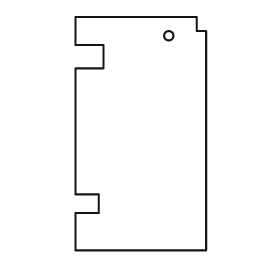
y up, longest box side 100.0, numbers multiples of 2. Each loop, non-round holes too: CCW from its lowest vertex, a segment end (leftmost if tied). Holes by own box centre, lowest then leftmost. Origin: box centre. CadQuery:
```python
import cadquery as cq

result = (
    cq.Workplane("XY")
    .moveTo(-28.0, -50.0)
    .lineTo(28.0, -50.0)
    .lineTo(28.0, 44.0)
    .lineTo(24.0, 44.0)
    .lineTo(24.0, 50.0)
    .lineTo(-28.0, 50.0)
    .lineTo(-28.0, 38.0)
    .lineTo(-16.0, 38.0)
    .lineTo(-16.0, 28.0)
    .lineTo(-28.0, 28.0)
    .lineTo(-28.0, -26.0)
    .lineTo(-18.0, -26.0)
    .lineTo(-18.0, -34.0)
    .lineTo(-28.0, -34.0)
    .close()
    .moveTo(12.0, 42.0)
    .circle(2.0)
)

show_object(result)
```